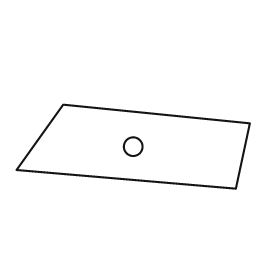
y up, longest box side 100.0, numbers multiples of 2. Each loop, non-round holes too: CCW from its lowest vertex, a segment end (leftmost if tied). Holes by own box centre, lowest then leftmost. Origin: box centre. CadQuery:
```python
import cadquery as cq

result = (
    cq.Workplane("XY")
    .moveTo(44.0, -18.0)
    .lineTo(50.0, 10.0)
    .lineTo(-30.0, 18.0)
    .lineTo(-50.0, -10.0)
    .close()
    .moveTo(0.0, 0.0)
    .circle(4.0)
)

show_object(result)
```